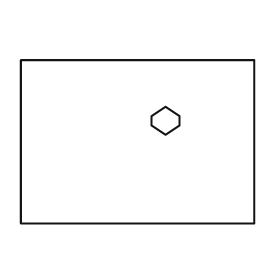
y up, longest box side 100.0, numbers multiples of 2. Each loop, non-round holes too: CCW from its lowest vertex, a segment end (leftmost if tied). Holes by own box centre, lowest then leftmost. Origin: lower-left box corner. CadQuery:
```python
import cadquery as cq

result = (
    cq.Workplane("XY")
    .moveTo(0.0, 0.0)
    .lineTo(100.0, 0.0)
    .lineTo(100.0, 70.0)
    .lineTo(0.0, 70.0)
    .close()
    .moveTo(62.0, 38.0)
    .lineTo(68.0, 42.0)
    .lineTo(68.0, 46.0)
    .lineTo(62.0, 50.0)
    .lineTo(56.0, 46.0)
    .lineTo(56.0, 42.0)
    .close()
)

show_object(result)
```